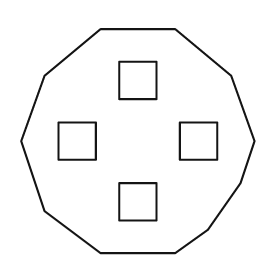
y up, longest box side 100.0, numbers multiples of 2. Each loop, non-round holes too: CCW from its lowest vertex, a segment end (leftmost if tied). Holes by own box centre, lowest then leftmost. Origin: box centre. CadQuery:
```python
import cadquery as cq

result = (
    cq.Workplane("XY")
    .moveTo(-16.0, -48.0)
    .lineTo(16.0, -48.0)
    .lineTo(30.0, -38.0)
    .lineTo(44.0, -18.0)
    .lineTo(50.0, 0.0)
    .lineTo(40.0, 28.0)
    .lineTo(16.0, 48.0)
    .lineTo(-16.0, 48.0)
    .lineTo(-40.0, 28.0)
    .lineTo(-50.0, 0.0)
    .lineTo(-40.0, -30.0)
    .close()
    .moveTo(-8.0, -34.0)
    .lineTo(8.0, -34.0)
    .lineTo(8.0, -18.0)
    .lineTo(-8.0, -18.0)
    .close()
    .moveTo(-34.0, -8.0)
    .lineTo(-18.0, -8.0)
    .lineTo(-18.0, 8.0)
    .lineTo(-34.0, 8.0)
    .close()
    .moveTo(18.0, -8.0)
    .lineTo(34.0, -8.0)
    .lineTo(34.0, 8.0)
    .lineTo(18.0, 8.0)
    .close()
    .moveTo(-8.0, 18.0)
    .lineTo(8.0, 18.0)
    .lineTo(8.0, 34.0)
    .lineTo(-8.0, 34.0)
    .close()
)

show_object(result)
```